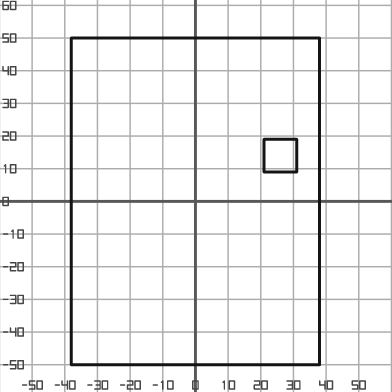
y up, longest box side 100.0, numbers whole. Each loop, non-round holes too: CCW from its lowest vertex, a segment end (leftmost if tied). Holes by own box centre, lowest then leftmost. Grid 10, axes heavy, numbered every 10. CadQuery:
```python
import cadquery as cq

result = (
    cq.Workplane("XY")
    .moveTo(-38.0, -50.0)
    .lineTo(38.0, -50.0)
    .lineTo(38.0, 50.0)
    .lineTo(-38.0, 50.0)
    .close()
    .moveTo(21.0, 9.0)
    .lineTo(31.0, 9.0)
    .lineTo(31.0, 19.0)
    .lineTo(21.0, 19.0)
    .close()
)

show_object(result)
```